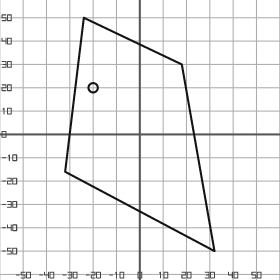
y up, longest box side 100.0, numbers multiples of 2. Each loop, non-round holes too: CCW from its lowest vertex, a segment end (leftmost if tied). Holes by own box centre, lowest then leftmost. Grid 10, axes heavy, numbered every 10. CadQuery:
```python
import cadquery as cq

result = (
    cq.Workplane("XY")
    .moveTo(32.0, -50.0)
    .lineTo(18.0, 30.0)
    .lineTo(-24.0, 50.0)
    .lineTo(-32.0, -16.0)
    .close()
    .moveTo(-20.0, 20.0)
    .circle(2.0)
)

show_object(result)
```